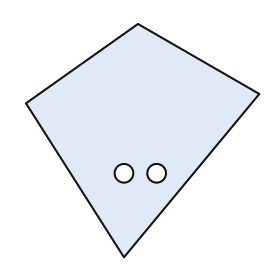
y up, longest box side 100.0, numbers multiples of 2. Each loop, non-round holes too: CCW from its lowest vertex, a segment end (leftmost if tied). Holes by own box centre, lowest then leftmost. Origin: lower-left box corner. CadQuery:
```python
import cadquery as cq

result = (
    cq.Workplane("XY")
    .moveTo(42.0, 0.0)
    .lineTo(100.0, 70.0)
    .lineTo(48.0, 100.0)
    .lineTo(0.0, 66.0)
    .close()
    .moveTo(42.0, 36.0)
    .circle(4.0)
    .moveTo(56.0, 36.0)
    .circle(4.0)
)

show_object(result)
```